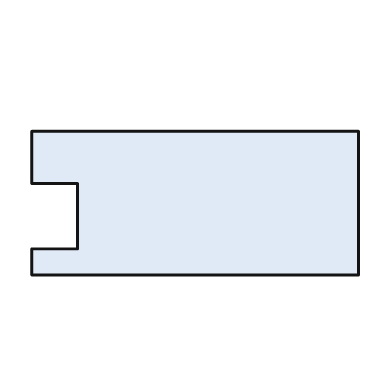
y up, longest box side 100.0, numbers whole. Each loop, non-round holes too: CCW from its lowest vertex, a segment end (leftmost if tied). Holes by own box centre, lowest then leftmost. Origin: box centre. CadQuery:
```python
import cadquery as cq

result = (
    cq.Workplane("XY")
    .moveTo(-50.0, -22.0)
    .lineTo(50.0, -22.0)
    .lineTo(50.0, 22.0)
    .lineTo(-50.0, 22.0)
    .lineTo(-50.0, 6.0)
    .lineTo(-36.0, 6.0)
    .lineTo(-36.0, -14.0)
    .lineTo(-50.0, -14.0)
    .close()
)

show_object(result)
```